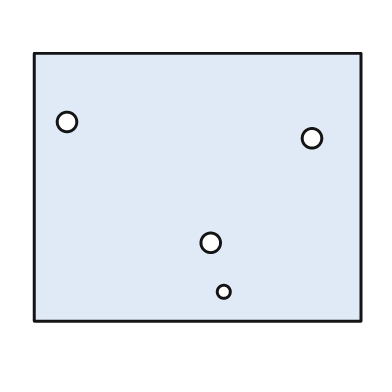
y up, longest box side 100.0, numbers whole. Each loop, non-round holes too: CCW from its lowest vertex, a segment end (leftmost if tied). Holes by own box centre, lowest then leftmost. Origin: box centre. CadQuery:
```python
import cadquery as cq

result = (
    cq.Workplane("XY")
    .moveTo(-50.0, -41.0)
    .lineTo(50.0, -41.0)
    .lineTo(50.0, 41.0)
    .lineTo(-50.0, 41.0)
    .close()
    .moveTo(8.0, -32.0)
    .circle(2.0)
    .moveTo(4.0, -17.0)
    .circle(3.0)
    .moveTo(35.0, 15.0)
    .circle(3.0)
    .moveTo(-40.0, 20.0)
    .circle(3.0)
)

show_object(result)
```